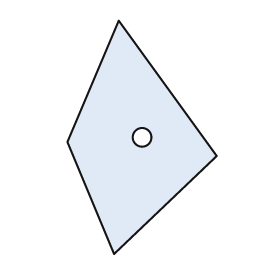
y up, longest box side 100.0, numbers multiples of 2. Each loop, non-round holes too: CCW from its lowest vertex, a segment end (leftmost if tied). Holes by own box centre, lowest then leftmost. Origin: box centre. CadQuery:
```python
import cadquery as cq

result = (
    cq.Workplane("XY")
    .moveTo(-12.0, -50.0)
    .lineTo(32.0, -8.0)
    .lineTo(-10.0, 50.0)
    .lineTo(-32.0, -2.0)
    .close()
    .moveTo(0.0, 0.0)
    .circle(4.0)
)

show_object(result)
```